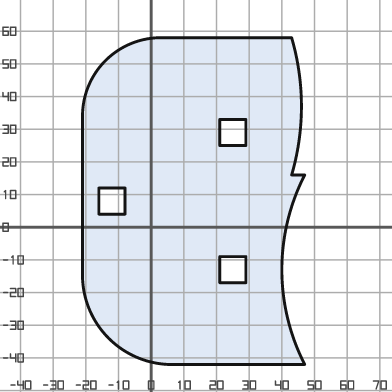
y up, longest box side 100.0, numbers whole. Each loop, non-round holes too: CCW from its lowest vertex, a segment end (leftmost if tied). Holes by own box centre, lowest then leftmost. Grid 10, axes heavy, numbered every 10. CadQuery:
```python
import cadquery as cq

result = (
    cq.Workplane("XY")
    .moveTo(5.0, -42.0)
    .lineTo(47.0, -42.0)
    .threePointArc((40.0, -13.0), (47.0, 16.0))
    .lineTo(43.0, 16.0)
    .threePointArc((46.0, 37.0), (43.0, 58.0))
    .lineTo(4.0, 58.0)
    .threePointArc((-14.0, 51.0), (-21.0, 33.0))
    .lineTo(-21.0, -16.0)
    .threePointArc((-13.0, -34.0), (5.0, -42.0))
    .close()
    .moveTo(21.0, -17.0)
    .lineTo(29.0, -17.0)
    .lineTo(29.0, -9.0)
    .lineTo(21.0, -9.0)
    .close()
    .moveTo(-16.0, 4.0)
    .lineTo(-8.0, 4.0)
    .lineTo(-8.0, 12.0)
    .lineTo(-16.0, 12.0)
    .close()
    .moveTo(21.0, 25.0)
    .lineTo(29.0, 25.0)
    .lineTo(29.0, 33.0)
    .lineTo(21.0, 33.0)
    .close()
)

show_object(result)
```